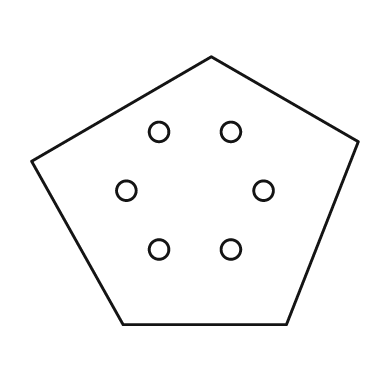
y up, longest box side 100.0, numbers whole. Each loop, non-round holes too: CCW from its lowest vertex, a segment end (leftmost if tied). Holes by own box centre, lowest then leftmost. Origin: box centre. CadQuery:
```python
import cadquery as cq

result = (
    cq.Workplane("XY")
    .moveTo(-22.0, -41.0)
    .lineTo(28.0, -41.0)
    .lineTo(50.0, 15.0)
    .lineTo(5.0, 41.0)
    .lineTo(-50.0, 9.0)
    .close()
    .moveTo(-11.0, -18.0)
    .circle(3.0)
    .moveTo(11.0, -18.0)
    .circle(3.0)
    .moveTo(-21.0, 0.0)
    .circle(3.0)
    .moveTo(21.0, 0.0)
    .circle(3.0)
    .moveTo(-11.0, 18.0)
    .circle(3.0)
    .moveTo(11.0, 18.0)
    .circle(3.0)
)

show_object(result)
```